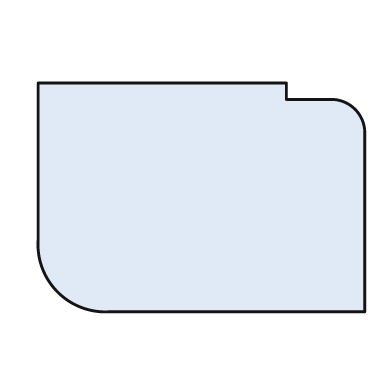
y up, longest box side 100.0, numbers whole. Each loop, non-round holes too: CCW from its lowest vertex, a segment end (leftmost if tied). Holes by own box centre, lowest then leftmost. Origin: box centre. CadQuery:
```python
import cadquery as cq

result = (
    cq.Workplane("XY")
    .moveTo(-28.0, -35.0)
    .lineTo(50.0, -35.0)
    .lineTo(50.0, 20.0)
    .threePointArc((47.0, 27.0), (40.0, 30.0))
    .lineTo(26.0, 30.0)
    .lineTo(26.0, 35.0)
    .lineTo(-50.0, 35.0)
    .lineTo(-50.0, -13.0)
    .threePointArc((-44.0, -29.0), (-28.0, -35.0))
    .close()
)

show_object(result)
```